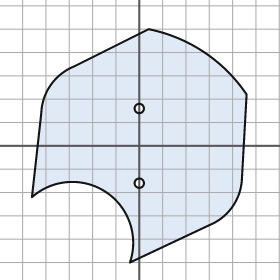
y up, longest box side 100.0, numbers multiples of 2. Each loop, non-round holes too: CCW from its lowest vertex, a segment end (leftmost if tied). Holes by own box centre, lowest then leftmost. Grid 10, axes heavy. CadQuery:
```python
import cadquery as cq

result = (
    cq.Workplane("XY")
    .moveTo(-4.0, -50.0)
    .lineTo(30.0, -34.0)
    .threePointArc((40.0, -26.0), (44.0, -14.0))
    .lineTo(46.0, 22.0)
    .threePointArc((28.0, 40.0), (4.0, 50.0))
    .lineTo(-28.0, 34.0)
    .threePointArc((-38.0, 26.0), (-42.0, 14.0))
    .lineTo(-46.0, -22.0)
    .threePointArc((-14.0, -20.0), (-4.0, -50.0))
    .close()
    .moveTo(0.0, -16.0)
    .circle(2.0)
    .moveTo(0.0, 16.0)
    .circle(2.0)
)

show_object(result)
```